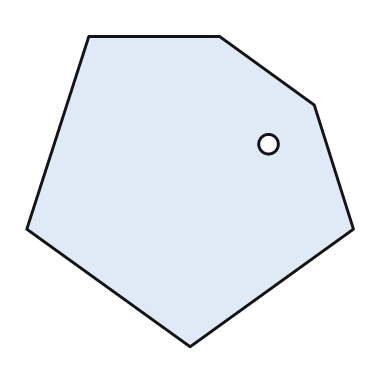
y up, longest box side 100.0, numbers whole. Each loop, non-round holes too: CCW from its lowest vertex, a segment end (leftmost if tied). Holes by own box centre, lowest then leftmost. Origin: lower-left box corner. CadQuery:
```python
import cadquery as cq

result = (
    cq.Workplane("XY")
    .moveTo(50.0, 0.0)
    .lineTo(100.0, 36.0)
    .lineTo(88.0, 74.0)
    .lineTo(59.0, 95.0)
    .lineTo(19.0, 95.0)
    .lineTo(0.0, 36.0)
    .close()
    .moveTo(74.0, 62.0)
    .circle(3.0)
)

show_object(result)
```